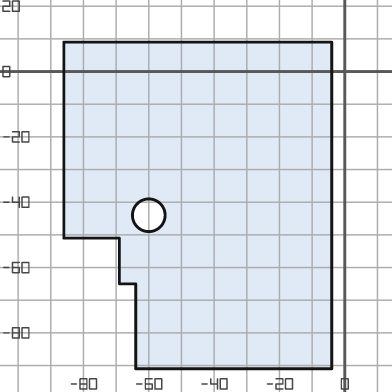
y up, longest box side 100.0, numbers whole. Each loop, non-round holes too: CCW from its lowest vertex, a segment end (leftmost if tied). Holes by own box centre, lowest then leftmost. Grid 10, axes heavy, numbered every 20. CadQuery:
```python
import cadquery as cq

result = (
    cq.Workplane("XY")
    .moveTo(-64.0, -91.0)
    .lineTo(-4.0, -91.0)
    .lineTo(-4.0, 9.0)
    .lineTo(-86.0, 9.0)
    .lineTo(-86.0, -51.0)
    .lineTo(-69.0, -51.0)
    .lineTo(-69.0, -65.0)
    .lineTo(-64.0, -65.0)
    .close()
    .moveTo(-60.0, -44.0)
    .circle(5.0)
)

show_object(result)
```